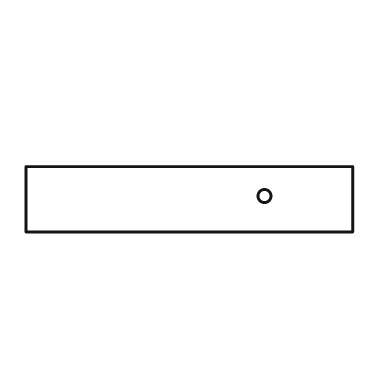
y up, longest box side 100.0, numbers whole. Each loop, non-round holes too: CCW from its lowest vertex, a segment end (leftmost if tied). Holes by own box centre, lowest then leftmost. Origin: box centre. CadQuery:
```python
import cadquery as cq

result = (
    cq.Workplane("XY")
    .moveTo(-50.0, -10.0)
    .lineTo(50.0, -10.0)
    .lineTo(50.0, 10.0)
    .lineTo(-50.0, 10.0)
    .close()
    .moveTo(23.0, 1.0)
    .circle(2.0)
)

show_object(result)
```